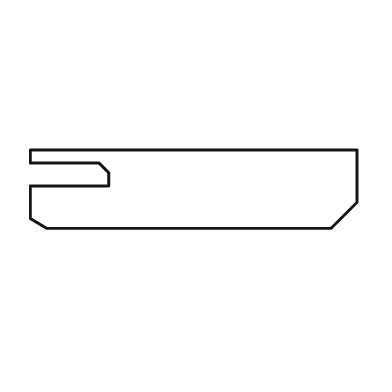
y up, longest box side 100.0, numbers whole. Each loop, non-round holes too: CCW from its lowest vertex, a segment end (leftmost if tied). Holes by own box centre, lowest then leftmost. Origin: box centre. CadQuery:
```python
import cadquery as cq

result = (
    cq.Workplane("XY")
    .moveTo(-45.0, -12.0)
    .lineTo(42.0, -12.0)
    .lineTo(50.0, -4.0)
    .lineTo(50.0, 12.0)
    .lineTo(-50.0, 12.0)
    .lineTo(-50.0, 8.0)
    .lineTo(-29.0, 8.0)
    .lineTo(-26.0, 5.0)
    .lineTo(-26.0, 1.0)
    .lineTo(-50.0, 1.0)
    .lineTo(-50.0, -9.0)
    .close()
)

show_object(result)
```